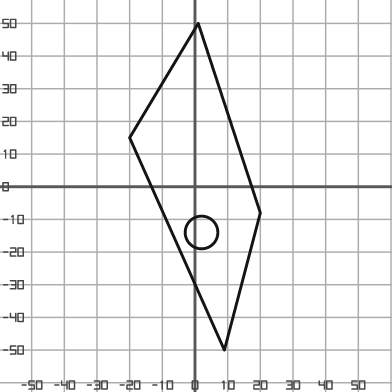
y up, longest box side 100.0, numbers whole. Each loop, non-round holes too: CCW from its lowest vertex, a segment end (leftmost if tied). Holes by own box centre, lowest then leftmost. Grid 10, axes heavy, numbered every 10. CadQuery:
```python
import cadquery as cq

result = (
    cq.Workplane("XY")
    .moveTo(9.0, -50.0)
    .lineTo(20.0, -8.0)
    .lineTo(1.0, 50.0)
    .lineTo(-20.0, 15.0)
    .close()
    .moveTo(2.0, -14.0)
    .circle(5.0)
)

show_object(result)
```